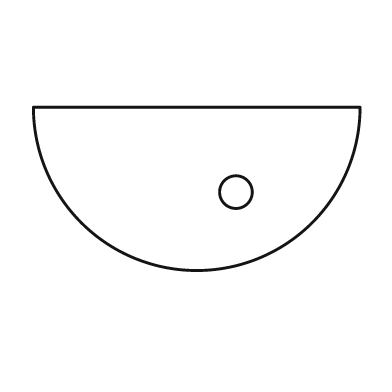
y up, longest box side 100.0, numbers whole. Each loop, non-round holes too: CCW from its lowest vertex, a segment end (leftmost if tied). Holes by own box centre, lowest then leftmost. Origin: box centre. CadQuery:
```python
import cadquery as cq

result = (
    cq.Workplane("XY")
    .moveTo(-50.0, 25.0)
    .threePointArc((0.0, -25.0), (50.0, 25.0))
    .close()
    .moveTo(12.0, -1.0)
    .circle(5.0)
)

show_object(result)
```